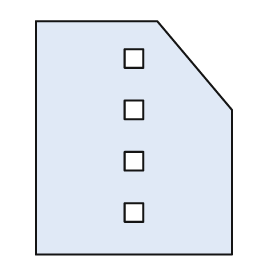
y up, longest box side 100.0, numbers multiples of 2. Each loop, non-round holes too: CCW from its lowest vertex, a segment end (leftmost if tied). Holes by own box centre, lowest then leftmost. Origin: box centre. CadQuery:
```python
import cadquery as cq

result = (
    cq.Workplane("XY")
    .moveTo(-42.0, -50.0)
    .lineTo(42.0, -50.0)
    .lineTo(42.0, 12.0)
    .lineTo(10.0, 50.0)
    .lineTo(-42.0, 50.0)
    .close()
    .moveTo(-4.0, -36.0)
    .lineTo(4.0, -36.0)
    .lineTo(4.0, -28.0)
    .lineTo(-4.0, -28.0)
    .close()
    .moveTo(-4.0, -14.0)
    .lineTo(4.0, -14.0)
    .lineTo(4.0, -6.0)
    .lineTo(-4.0, -6.0)
    .close()
    .moveTo(-4.0, 8.0)
    .lineTo(4.0, 8.0)
    .lineTo(4.0, 16.0)
    .lineTo(-4.0, 16.0)
    .close()
    .moveTo(-4.0, 30.0)
    .lineTo(4.0, 30.0)
    .lineTo(4.0, 38.0)
    .lineTo(-4.0, 38.0)
    .close()
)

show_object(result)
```